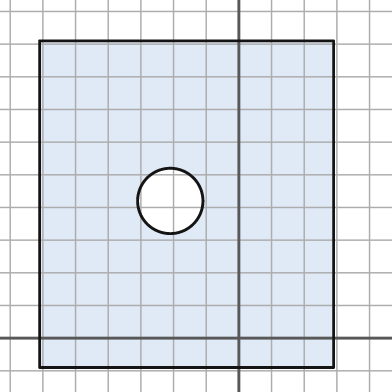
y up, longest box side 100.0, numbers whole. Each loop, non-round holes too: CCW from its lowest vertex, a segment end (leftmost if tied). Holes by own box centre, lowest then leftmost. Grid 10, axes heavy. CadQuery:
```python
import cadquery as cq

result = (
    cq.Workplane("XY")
    .moveTo(-61.0, -9.0)
    .lineTo(29.0, -9.0)
    .lineTo(29.0, 91.0)
    .lineTo(-61.0, 91.0)
    .close()
    .moveTo(-21.0, 42.0)
    .circle(10.0)
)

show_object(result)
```